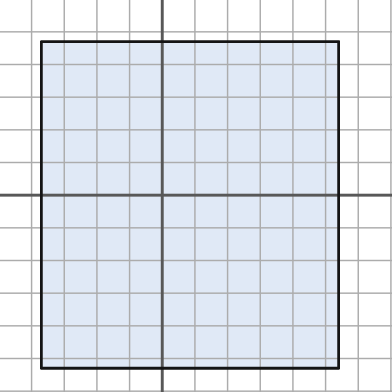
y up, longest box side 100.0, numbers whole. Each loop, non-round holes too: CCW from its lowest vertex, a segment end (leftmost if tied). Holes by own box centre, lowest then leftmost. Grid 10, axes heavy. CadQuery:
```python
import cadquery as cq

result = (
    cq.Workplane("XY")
    .moveTo(-37.0, -53.0)
    .lineTo(54.0, -53.0)
    .lineTo(54.0, 47.0)
    .lineTo(-37.0, 47.0)
    .close()
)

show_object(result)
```